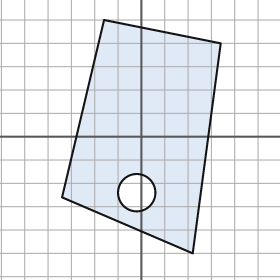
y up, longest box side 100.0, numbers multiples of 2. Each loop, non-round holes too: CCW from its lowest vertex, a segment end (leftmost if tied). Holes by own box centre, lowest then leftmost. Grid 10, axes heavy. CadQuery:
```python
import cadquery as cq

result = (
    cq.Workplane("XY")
    .moveTo(22.0, -50.0)
    .lineTo(34.0, 40.0)
    .lineTo(-16.0, 50.0)
    .lineTo(-34.0, -26.0)
    .close()
    .moveTo(-2.0, -24.0)
    .circle(8.0)
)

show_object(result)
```